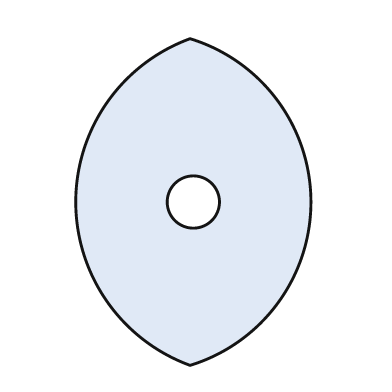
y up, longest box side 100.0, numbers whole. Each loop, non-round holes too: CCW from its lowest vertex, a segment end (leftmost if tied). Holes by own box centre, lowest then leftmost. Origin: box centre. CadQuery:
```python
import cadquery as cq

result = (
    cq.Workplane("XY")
    .moveTo(-1.0, -50.0)
    .threePointArc((36.0, 0.0), (-1.0, 50.0))
    .threePointArc((-36.0, 0.0), (-1.0, -50.0))
    .close()
    .moveTo(0.0, 0.0)
    .circle(8.0)
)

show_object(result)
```